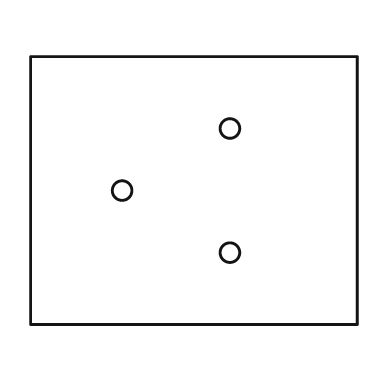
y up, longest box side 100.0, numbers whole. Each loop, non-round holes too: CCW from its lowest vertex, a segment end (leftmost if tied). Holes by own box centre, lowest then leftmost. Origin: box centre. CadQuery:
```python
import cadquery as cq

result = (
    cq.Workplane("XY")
    .moveTo(-50.0, -41.0)
    .lineTo(50.0, -41.0)
    .lineTo(50.0, 41.0)
    .lineTo(-50.0, 41.0)
    .close()
    .moveTo(11.0, -19.0)
    .circle(3.0)
    .moveTo(-22.0, 0.0)
    .circle(3.0)
    .moveTo(11.0, 19.0)
    .circle(3.0)
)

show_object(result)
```